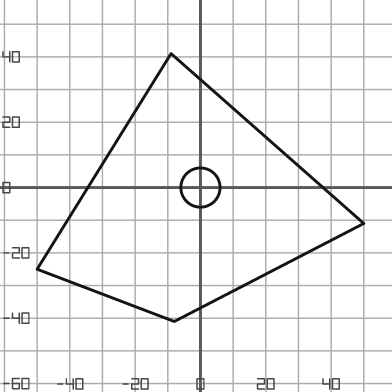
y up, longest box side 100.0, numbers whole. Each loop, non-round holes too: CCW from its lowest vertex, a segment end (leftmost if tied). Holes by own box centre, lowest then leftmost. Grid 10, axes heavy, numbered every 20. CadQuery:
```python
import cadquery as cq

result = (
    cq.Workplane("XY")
    .moveTo(-8.0, -41.0)
    .lineTo(50.0, -11.0)
    .lineTo(-9.0, 41.0)
    .lineTo(-50.0, -25.0)
    .close()
    .moveTo(0.0, 0.0)
    .circle(6.0)
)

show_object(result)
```